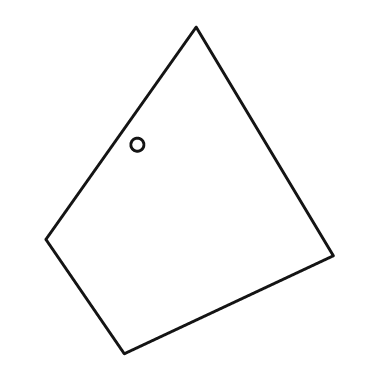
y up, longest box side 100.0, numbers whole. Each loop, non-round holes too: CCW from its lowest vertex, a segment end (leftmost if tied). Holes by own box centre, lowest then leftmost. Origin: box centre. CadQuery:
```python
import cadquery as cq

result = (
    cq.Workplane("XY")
    .moveTo(-20.0, -50.0)
    .lineTo(44.0, -20.0)
    .lineTo(2.0, 50.0)
    .lineTo(-44.0, -15.0)
    .close()
    .moveTo(-16.0, 14.0)
    .circle(2.0)
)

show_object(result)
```